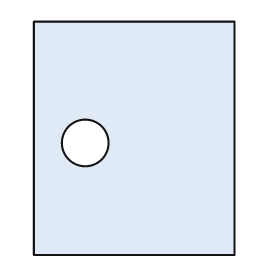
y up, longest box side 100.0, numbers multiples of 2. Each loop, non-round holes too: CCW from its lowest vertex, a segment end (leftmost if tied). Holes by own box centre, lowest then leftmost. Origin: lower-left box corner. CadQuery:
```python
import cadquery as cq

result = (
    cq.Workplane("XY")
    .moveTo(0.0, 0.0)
    .lineTo(86.0, 0.0)
    .lineTo(86.0, 100.0)
    .lineTo(0.0, 100.0)
    .close()
    .moveTo(22.0, 48.0)
    .circle(10.0)
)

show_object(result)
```